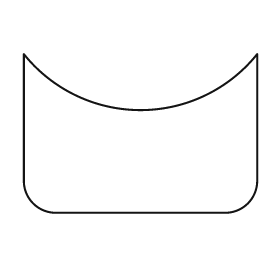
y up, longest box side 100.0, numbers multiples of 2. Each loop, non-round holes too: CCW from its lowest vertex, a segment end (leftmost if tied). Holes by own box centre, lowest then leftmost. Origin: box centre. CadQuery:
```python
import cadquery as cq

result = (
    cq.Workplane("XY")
    .moveTo(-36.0, -34.0)
    .lineTo(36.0, -34.0)
    .threePointArc((46.0, -30.0), (50.0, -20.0))
    .lineTo(50.0, 34.0)
    .threePointArc((0.0, 10.0), (-50.0, 34.0))
    .lineTo(-50.0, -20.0)
    .threePointArc((-46.0, -30.0), (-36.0, -34.0))
    .close()
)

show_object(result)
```